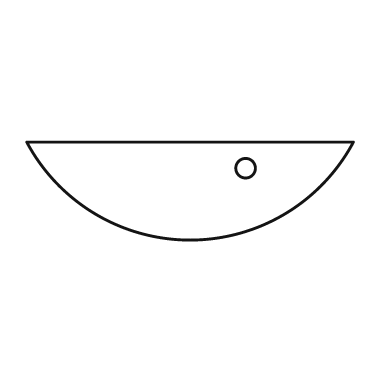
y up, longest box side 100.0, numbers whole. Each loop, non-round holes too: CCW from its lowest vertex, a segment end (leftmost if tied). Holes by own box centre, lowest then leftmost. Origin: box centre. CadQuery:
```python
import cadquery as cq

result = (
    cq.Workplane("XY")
    .moveTo(-50.0, 15.0)
    .threePointArc((0.0, -15.0), (50.0, 15.0))
    .close()
    .moveTo(17.0, 7.0)
    .circle(3.0)
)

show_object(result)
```